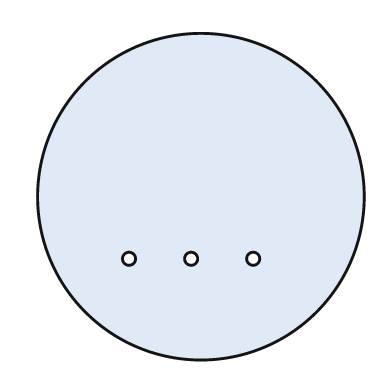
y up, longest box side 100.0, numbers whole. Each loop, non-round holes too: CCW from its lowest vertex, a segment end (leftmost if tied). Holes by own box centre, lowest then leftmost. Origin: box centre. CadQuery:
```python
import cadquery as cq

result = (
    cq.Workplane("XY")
    .moveTo(0.0, 0.0)
    .circle(50.0)
    .moveTo(-22.0, -19.0)
    .circle(2.0)
    .moveTo(-3.0, -19.0)
    .circle(2.0)
    .moveTo(16.0, -19.0)
    .circle(2.0)
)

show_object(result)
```